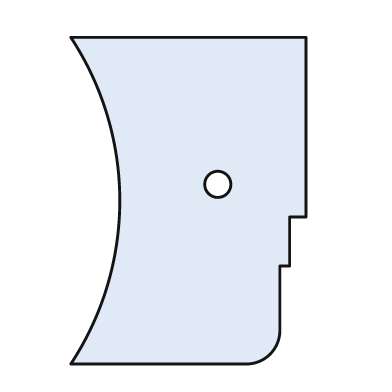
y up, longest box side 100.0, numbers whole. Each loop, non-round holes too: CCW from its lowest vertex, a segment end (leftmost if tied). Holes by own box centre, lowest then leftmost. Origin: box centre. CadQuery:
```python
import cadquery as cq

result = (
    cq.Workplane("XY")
    .moveTo(-36.0, -50.0)
    .lineTo(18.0, -50.0)
    .threePointArc((25.0, -47.0), (28.0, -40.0))
    .lineTo(28.0, -20.0)
    .lineTo(31.0, -20.0)
    .lineTo(31.0, -5.0)
    .lineTo(36.0, -5.0)
    .lineTo(36.0, 50.0)
    .lineTo(-36.0, 50.0)
    .threePointArc((-21.0, 0.0), (-36.0, -50.0))
    .close()
    .moveTo(9.0, 5.0)
    .circle(4.0)
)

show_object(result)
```